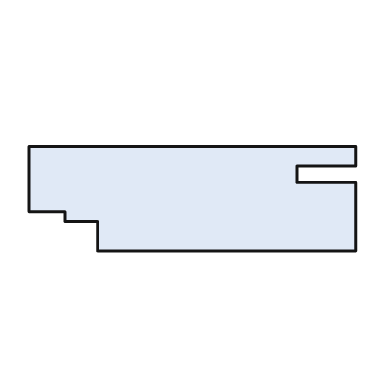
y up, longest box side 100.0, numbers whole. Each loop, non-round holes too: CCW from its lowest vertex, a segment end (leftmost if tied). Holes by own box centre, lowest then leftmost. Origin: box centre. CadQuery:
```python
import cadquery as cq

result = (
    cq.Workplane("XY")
    .moveTo(-29.0, -16.0)
    .lineTo(50.0, -16.0)
    .lineTo(50.0, 5.0)
    .lineTo(32.0, 5.0)
    .lineTo(32.0, 10.0)
    .lineTo(50.0, 10.0)
    .lineTo(50.0, 16.0)
    .lineTo(-50.0, 16.0)
    .lineTo(-50.0, -4.0)
    .lineTo(-39.0, -4.0)
    .lineTo(-39.0, -7.0)
    .lineTo(-29.0, -7.0)
    .close()
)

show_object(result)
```